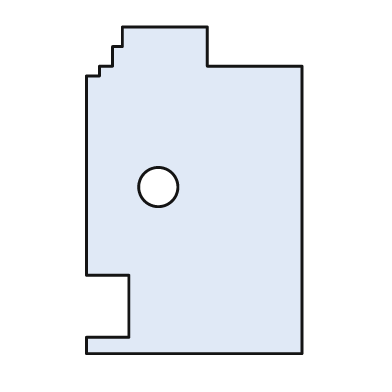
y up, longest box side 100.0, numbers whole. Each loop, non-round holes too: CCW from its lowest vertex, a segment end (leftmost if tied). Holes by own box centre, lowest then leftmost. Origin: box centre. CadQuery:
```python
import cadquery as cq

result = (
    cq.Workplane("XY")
    .moveTo(-33.0, -50.0)
    .lineTo(33.0, -50.0)
    .lineTo(33.0, 38.0)
    .lineTo(4.0, 38.0)
    .lineTo(4.0, 50.0)
    .lineTo(-22.0, 50.0)
    .lineTo(-22.0, 44.0)
    .lineTo(-25.0, 44.0)
    .lineTo(-25.0, 38.0)
    .lineTo(-29.0, 38.0)
    .lineTo(-29.0, 35.0)
    .lineTo(-33.0, 35.0)
    .lineTo(-33.0, -26.0)
    .lineTo(-20.0, -26.0)
    .lineTo(-20.0, -45.0)
    .lineTo(-33.0, -45.0)
    .close()
    .moveTo(-11.0, 1.0)
    .circle(6.0)
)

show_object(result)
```